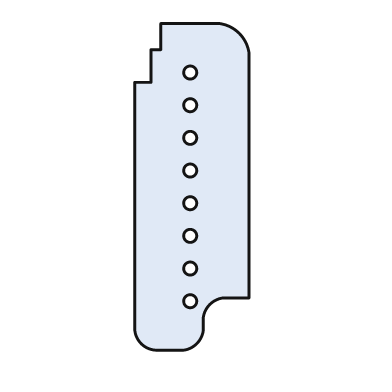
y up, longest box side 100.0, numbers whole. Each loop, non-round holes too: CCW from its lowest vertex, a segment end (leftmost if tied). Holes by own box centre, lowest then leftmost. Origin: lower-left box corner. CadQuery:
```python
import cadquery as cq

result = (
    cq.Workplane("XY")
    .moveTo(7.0, 0.0)
    .lineTo(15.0, 0.0)
    .threePointArc((19.0, 2.0), (21.0, 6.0))
    .lineTo(21.0, 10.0)
    .threePointArc((23.0, 14.0), (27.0, 16.0))
    .lineTo(35.0, 16.0)
    .lineTo(35.0, 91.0)
    .threePointArc((32.0, 97.0), (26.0, 100.0))
    .lineTo(8.0, 100.0)
    .lineTo(8.0, 92.0)
    .lineTo(5.0, 92.0)
    .lineTo(5.0, 82.0)
    .lineTo(0.0, 82.0)
    .lineTo(0.0, 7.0)
    .threePointArc((2.0, 2.0), (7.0, 0.0))
    .close()
    .moveTo(17.0, 15.0)
    .circle(2.0)
    .moveTo(17.0, 25.0)
    .circle(2.0)
    .moveTo(17.0, 35.0)
    .circle(2.0)
    .moveTo(17.0, 45.0)
    .circle(2.0)
    .moveTo(17.0, 55.0)
    .circle(2.0)
    .moveTo(17.0, 65.0)
    .circle(2.0)
    .moveTo(17.0, 75.0)
    .circle(2.0)
    .moveTo(17.0, 85.0)
    .circle(2.0)
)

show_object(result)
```